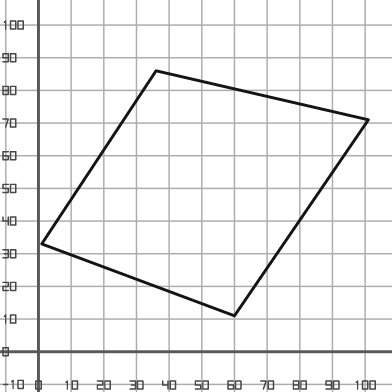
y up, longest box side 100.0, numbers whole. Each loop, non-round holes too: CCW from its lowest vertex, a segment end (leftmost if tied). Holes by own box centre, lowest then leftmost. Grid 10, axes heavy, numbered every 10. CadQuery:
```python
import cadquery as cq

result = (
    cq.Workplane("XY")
    .moveTo(60.0, 11.0)
    .lineTo(101.0, 71.0)
    .lineTo(36.0, 86.0)
    .lineTo(1.0, 33.0)
    .close()
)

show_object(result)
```